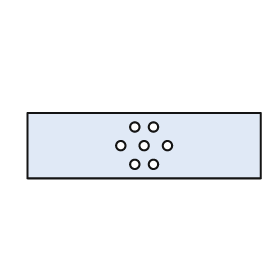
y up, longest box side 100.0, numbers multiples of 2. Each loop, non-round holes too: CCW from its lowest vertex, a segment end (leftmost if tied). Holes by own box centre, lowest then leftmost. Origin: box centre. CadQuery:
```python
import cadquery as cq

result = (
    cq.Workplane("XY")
    .moveTo(-50.0, -14.0)
    .lineTo(50.0, -14.0)
    .lineTo(50.0, 14.0)
    .lineTo(-50.0, 14.0)
    .close()
    .moveTo(-4.0, -8.0)
    .circle(2.0)
    .moveTo(4.0, -8.0)
    .circle(2.0)
    .moveTo(-10.0, 0.0)
    .circle(2.0)
    .moveTo(0.0, 0.0)
    .circle(2.0)
    .moveTo(10.0, 0.0)
    .circle(2.0)
    .moveTo(-4.0, 8.0)
    .circle(2.0)
    .moveTo(4.0, 8.0)
    .circle(2.0)
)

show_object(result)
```